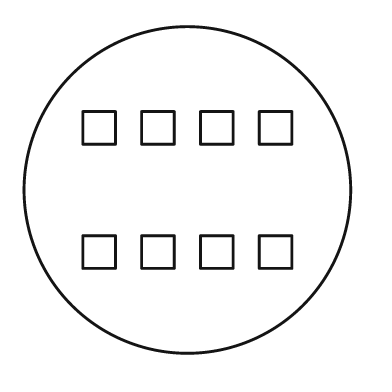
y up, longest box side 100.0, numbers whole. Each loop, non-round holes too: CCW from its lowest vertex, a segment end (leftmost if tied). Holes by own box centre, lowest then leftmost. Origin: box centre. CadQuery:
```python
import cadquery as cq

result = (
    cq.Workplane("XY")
    .moveTo(0.0, 0.0)
    .circle(50.0)
    .moveTo(-32.0, -24.0)
    .lineTo(-22.0, -24.0)
    .lineTo(-22.0, -14.0)
    .lineTo(-32.0, -14.0)
    .close()
    .moveTo(-14.0, -24.0)
    .lineTo(-4.0, -24.0)
    .lineTo(-4.0, -14.0)
    .lineTo(-14.0, -14.0)
    .close()
    .moveTo(4.0, -24.0)
    .lineTo(14.0, -24.0)
    .lineTo(14.0, -14.0)
    .lineTo(4.0, -14.0)
    .close()
    .moveTo(22.0, -24.0)
    .lineTo(32.0, -24.0)
    .lineTo(32.0, -14.0)
    .lineTo(22.0, -14.0)
    .close()
    .moveTo(-32.0, 14.0)
    .lineTo(-22.0, 14.0)
    .lineTo(-22.0, 24.0)
    .lineTo(-32.0, 24.0)
    .close()
    .moveTo(-14.0, 14.0)
    .lineTo(-4.0, 14.0)
    .lineTo(-4.0, 24.0)
    .lineTo(-14.0, 24.0)
    .close()
    .moveTo(4.0, 14.0)
    .lineTo(14.0, 14.0)
    .lineTo(14.0, 24.0)
    .lineTo(4.0, 24.0)
    .close()
    .moveTo(22.0, 14.0)
    .lineTo(32.0, 14.0)
    .lineTo(32.0, 24.0)
    .lineTo(22.0, 24.0)
    .close()
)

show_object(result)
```